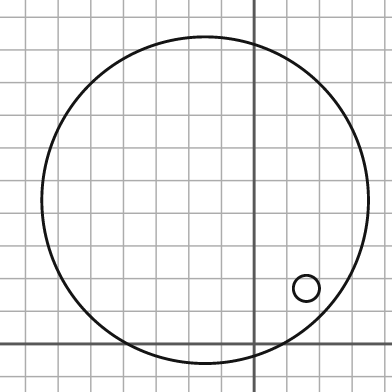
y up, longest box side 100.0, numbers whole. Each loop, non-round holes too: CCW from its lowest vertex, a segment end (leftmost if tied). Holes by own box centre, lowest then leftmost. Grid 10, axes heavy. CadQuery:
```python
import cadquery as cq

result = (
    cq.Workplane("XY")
    .moveTo(-15.0, 44.0)
    .circle(50.0)
    .moveTo(16.0, 17.0)
    .circle(4.0)
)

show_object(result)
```